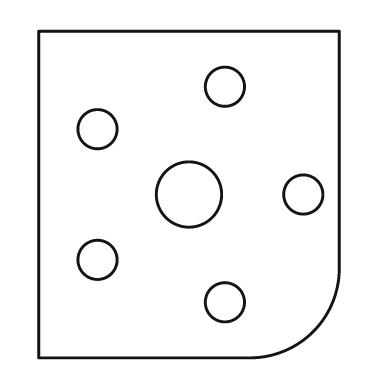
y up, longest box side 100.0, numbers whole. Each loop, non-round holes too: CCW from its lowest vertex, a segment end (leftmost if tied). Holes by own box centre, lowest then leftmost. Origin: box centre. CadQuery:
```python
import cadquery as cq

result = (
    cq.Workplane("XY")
    .moveTo(-46.0, -50.0)
    .lineTo(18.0, -50.0)
    .threePointArc((38.0, -42.0), (46.0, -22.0))
    .lineTo(46.0, 50.0)
    .lineTo(-46.0, 50.0)
    .close()
    .moveTo(11.0, -33.0)
    .circle(6.0)
    .moveTo(-28.0, -20.0)
    .circle(6.0)
    .moveTo(0.0, 0.0)
    .circle(10.0)
    .moveTo(35.0, 0.0)
    .circle(6.0)
    .moveTo(-28.0, 20.0)
    .circle(6.0)
    .moveTo(11.0, 33.0)
    .circle(6.0)
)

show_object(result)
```